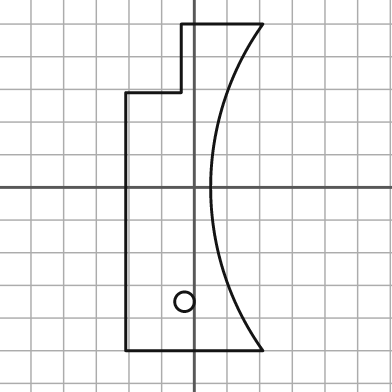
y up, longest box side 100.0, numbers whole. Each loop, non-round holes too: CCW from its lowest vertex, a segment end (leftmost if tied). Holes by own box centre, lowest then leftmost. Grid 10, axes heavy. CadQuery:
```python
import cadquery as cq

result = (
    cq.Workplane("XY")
    .moveTo(-21.0, -50.0)
    .lineTo(21.0, -50.0)
    .threePointArc((5.0, 0.0), (21.0, 50.0))
    .lineTo(-4.0, 50.0)
    .lineTo(-4.0, 29.0)
    .lineTo(-21.0, 29.0)
    .close()
    .moveTo(-3.0, -35.0)
    .circle(3.0)
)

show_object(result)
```